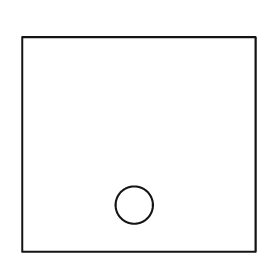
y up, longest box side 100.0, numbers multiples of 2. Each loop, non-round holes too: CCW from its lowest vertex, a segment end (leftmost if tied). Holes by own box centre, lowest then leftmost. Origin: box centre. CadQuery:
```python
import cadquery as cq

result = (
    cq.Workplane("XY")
    .moveTo(-50.0, -46.0)
    .lineTo(50.0, -46.0)
    .lineTo(50.0, 46.0)
    .lineTo(-50.0, 46.0)
    .close()
    .moveTo(-2.0, -26.0)
    .circle(8.0)
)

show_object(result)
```